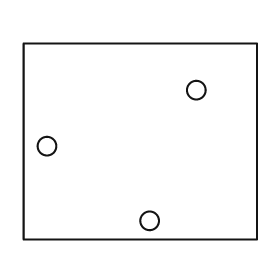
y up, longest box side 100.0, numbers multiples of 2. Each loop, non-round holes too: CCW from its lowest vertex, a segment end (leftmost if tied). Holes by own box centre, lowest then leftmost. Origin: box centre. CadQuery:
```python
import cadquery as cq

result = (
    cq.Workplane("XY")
    .moveTo(-50.0, -42.0)
    .lineTo(50.0, -42.0)
    .lineTo(50.0, 42.0)
    .lineTo(-50.0, 42.0)
    .close()
    .moveTo(4.0, -34.0)
    .circle(4.0)
    .moveTo(-40.0, -2.0)
    .circle(4.0)
    .moveTo(24.0, 22.0)
    .circle(4.0)
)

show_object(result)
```